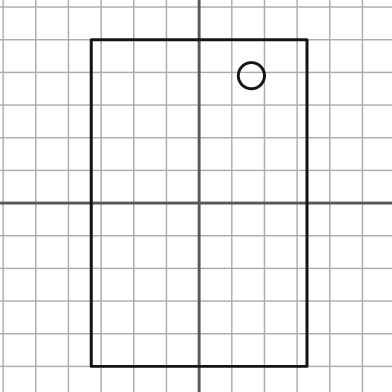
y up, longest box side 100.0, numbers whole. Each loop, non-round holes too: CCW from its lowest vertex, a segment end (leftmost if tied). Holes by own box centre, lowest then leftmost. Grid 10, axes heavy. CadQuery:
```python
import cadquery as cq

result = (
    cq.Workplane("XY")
    .moveTo(-33.0, -50.0)
    .lineTo(33.0, -50.0)
    .lineTo(33.0, 50.0)
    .lineTo(-33.0, 50.0)
    .close()
    .moveTo(16.0, 39.0)
    .circle(4.0)
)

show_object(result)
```